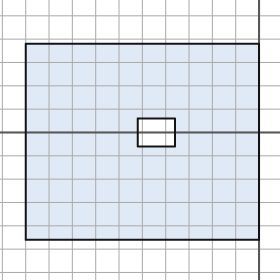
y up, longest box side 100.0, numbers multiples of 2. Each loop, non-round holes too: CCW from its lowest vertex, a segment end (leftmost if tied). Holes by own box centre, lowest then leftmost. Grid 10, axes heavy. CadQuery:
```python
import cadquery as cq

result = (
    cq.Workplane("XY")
    .moveTo(-100.0, -46.0)
    .lineTo(0.0, -46.0)
    .lineTo(0.0, 38.0)
    .lineTo(-100.0, 38.0)
    .close()
    .moveTo(-52.0, -6.0)
    .lineTo(-36.0, -6.0)
    .lineTo(-36.0, 6.0)
    .lineTo(-52.0, 6.0)
    .close()
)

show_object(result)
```